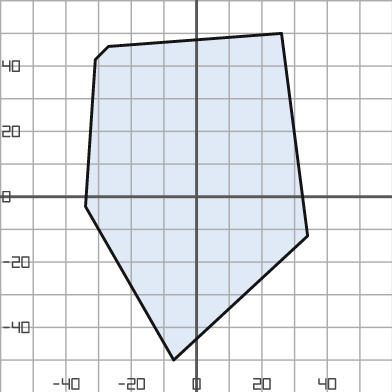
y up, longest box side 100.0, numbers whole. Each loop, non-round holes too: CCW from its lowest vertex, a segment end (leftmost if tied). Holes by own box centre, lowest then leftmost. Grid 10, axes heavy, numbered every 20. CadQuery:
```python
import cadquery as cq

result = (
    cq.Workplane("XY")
    .moveTo(-7.0, -50.0)
    .lineTo(34.0, -12.0)
    .lineTo(26.0, 50.0)
    .lineTo(-27.0, 46.0)
    .lineTo(-31.0, 42.0)
    .lineTo(-34.0, -3.0)
    .close()
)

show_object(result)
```